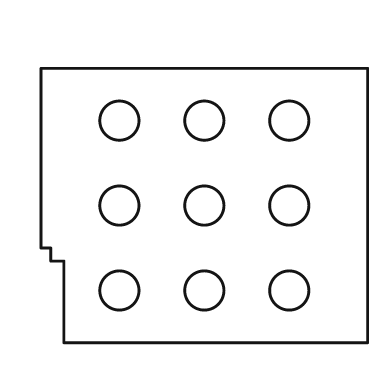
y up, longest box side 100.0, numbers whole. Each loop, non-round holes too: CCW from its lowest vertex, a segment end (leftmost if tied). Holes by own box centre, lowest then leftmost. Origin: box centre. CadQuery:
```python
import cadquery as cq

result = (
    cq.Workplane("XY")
    .moveTo(-43.0, -42.0)
    .lineTo(50.0, -42.0)
    .lineTo(50.0, 42.0)
    .lineTo(-50.0, 42.0)
    .lineTo(-50.0, -13.0)
    .lineTo(-47.0, -13.0)
    .lineTo(-47.0, -17.0)
    .lineTo(-43.0, -17.0)
    .close()
    .moveTo(-26.0, -26.0)
    .circle(6.0)
    .moveTo(0.0, -26.0)
    .circle(6.0)
    .moveTo(26.0, -26.0)
    .circle(6.0)
    .moveTo(-26.0, 0.0)
    .circle(6.0)
    .moveTo(0.0, 0.0)
    .circle(6.0)
    .moveTo(26.0, 0.0)
    .circle(6.0)
    .moveTo(-26.0, 26.0)
    .circle(6.0)
    .moveTo(0.0, 26.0)
    .circle(6.0)
    .moveTo(26.0, 26.0)
    .circle(6.0)
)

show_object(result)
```